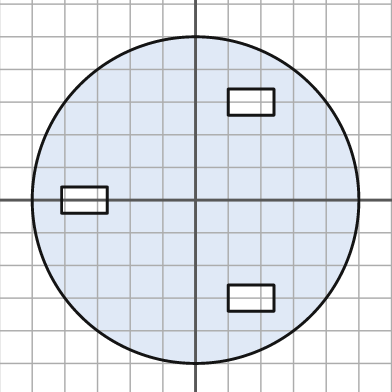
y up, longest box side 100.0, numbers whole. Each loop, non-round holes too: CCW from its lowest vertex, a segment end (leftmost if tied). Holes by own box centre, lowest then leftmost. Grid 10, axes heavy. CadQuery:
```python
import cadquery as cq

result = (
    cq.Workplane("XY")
    .moveTo(0.0, 0.0)
    .circle(50.0)
    .moveTo(10.0, -34.0)
    .lineTo(24.0, -34.0)
    .lineTo(24.0, -26.0)
    .lineTo(10.0, -26.0)
    .close()
    .moveTo(-41.0, -4.0)
    .lineTo(-27.0, -4.0)
    .lineTo(-27.0, 4.0)
    .lineTo(-41.0, 4.0)
    .close()
    .moveTo(10.0, 26.0)
    .lineTo(24.0, 26.0)
    .lineTo(24.0, 34.0)
    .lineTo(10.0, 34.0)
    .close()
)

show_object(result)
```